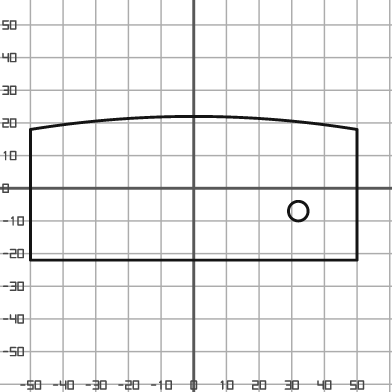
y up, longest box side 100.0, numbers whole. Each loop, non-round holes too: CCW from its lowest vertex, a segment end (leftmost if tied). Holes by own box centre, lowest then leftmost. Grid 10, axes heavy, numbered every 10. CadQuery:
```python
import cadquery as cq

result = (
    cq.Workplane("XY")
    .moveTo(-50.0, -22.0)
    .lineTo(50.0, -22.0)
    .lineTo(50.0, 18.0)
    .threePointArc((0.0, 22.0), (-50.0, 18.0))
    .close()
    .moveTo(32.0, -7.0)
    .circle(3.0)
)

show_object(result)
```